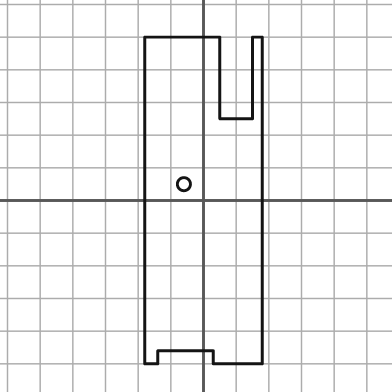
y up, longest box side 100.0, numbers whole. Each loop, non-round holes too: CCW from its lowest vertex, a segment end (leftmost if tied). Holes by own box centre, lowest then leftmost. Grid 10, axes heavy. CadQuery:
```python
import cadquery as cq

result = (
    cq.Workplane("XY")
    .moveTo(-18.0, -50.0)
    .lineTo(-14.0, -50.0)
    .lineTo(-14.0, -46.0)
    .lineTo(3.0, -46.0)
    .lineTo(3.0, -50.0)
    .lineTo(18.0, -50.0)
    .lineTo(18.0, 50.0)
    .lineTo(15.0, 50.0)
    .lineTo(15.0, 25.0)
    .lineTo(5.0, 25.0)
    .lineTo(5.0, 50.0)
    .lineTo(-18.0, 50.0)
    .close()
    .moveTo(-6.0, 5.0)
    .circle(2.0)
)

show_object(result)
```